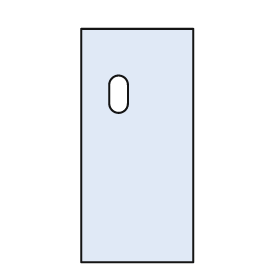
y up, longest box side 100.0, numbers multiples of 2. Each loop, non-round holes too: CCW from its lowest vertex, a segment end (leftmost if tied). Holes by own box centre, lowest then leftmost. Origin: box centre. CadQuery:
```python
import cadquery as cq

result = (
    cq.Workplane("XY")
    .moveTo(-24.0, -50.0)
    .lineTo(24.0, -50.0)
    .lineTo(24.0, 50.0)
    .lineTo(-24.0, 50.0)
    .close()
    .moveTo(-12.0, 18.0)
    .threePointArc((-8.0, 14.0), (-4.0, 18.0))
    .lineTo(-4.0, 26.0)
    .threePointArc((-8.0, 30.0), (-12.0, 26.0))
    .close()
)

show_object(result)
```